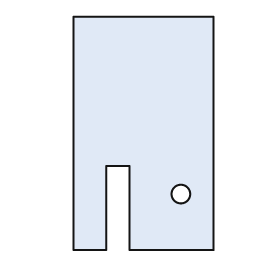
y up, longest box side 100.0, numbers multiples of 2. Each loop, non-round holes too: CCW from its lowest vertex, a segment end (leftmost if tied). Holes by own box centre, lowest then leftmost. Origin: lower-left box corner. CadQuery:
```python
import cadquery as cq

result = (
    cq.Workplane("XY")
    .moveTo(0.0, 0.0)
    .lineTo(14.0, 0.0)
    .lineTo(14.0, 36.0)
    .lineTo(24.0, 36.0)
    .lineTo(24.0, 0.0)
    .lineTo(60.0, 0.0)
    .lineTo(60.0, 100.0)
    .lineTo(0.0, 100.0)
    .close()
    .moveTo(46.0, 24.0)
    .circle(4.0)
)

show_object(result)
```